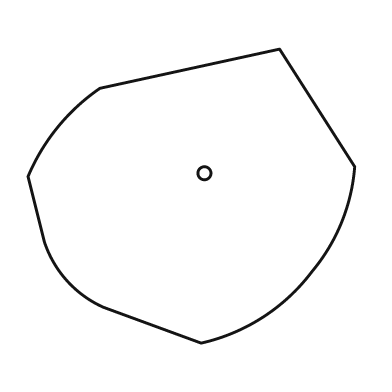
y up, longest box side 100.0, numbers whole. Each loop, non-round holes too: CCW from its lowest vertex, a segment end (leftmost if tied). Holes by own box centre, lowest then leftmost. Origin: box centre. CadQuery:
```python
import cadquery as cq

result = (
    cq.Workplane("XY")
    .moveTo(3.0, -45.0)
    .threePointArc((22.0, -37.0), (37.0, -23.0))
    .threePointArc((46.0, -8.0), (50.0, 9.0))
    .lineTo(27.0, 45.0)
    .lineTo(-28.0, 33.0)
    .threePointArc((-41.0, 21.0), (-50.0, 6.0))
    .lineTo(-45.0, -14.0)
    .threePointArc((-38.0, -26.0), (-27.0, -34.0))
    .close()
    .moveTo(4.0, 7.0)
    .circle(2.0)
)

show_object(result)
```